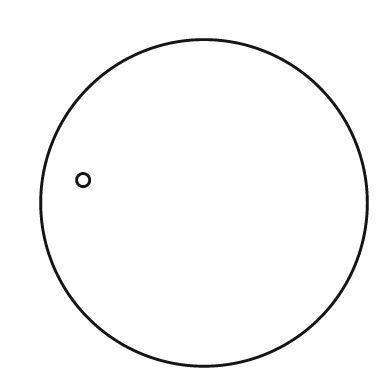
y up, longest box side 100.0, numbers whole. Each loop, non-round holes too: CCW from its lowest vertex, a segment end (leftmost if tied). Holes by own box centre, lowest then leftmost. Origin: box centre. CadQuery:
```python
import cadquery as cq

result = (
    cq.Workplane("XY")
    .moveTo(0.0, 0.0)
    .circle(50.0)
    .moveTo(-37.0, 7.0)
    .circle(2.0)
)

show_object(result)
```